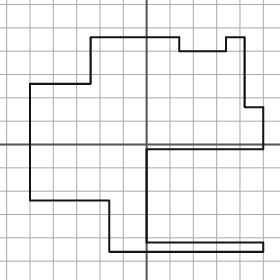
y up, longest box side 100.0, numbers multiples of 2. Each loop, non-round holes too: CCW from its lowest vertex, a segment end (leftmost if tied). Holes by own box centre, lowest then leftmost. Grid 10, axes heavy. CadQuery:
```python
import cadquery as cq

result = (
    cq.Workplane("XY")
    .moveTo(-16.0, -46.0)
    .lineTo(50.0, -46.0)
    .lineTo(50.0, -42.0)
    .lineTo(0.0, -42.0)
    .lineTo(0.0, -2.0)
    .lineTo(50.0, -2.0)
    .lineTo(50.0, 16.0)
    .lineTo(42.0, 16.0)
    .lineTo(42.0, 46.0)
    .lineTo(34.0, 46.0)
    .lineTo(34.0, 40.0)
    .lineTo(14.0, 40.0)
    .lineTo(14.0, 46.0)
    .lineTo(-24.0, 46.0)
    .lineTo(-24.0, 26.0)
    .lineTo(-50.0, 26.0)
    .lineTo(-50.0, -24.0)
    .lineTo(-16.0, -24.0)
    .close()
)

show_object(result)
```